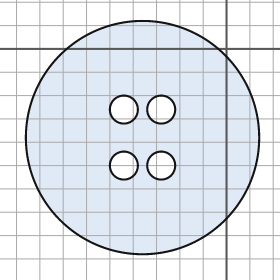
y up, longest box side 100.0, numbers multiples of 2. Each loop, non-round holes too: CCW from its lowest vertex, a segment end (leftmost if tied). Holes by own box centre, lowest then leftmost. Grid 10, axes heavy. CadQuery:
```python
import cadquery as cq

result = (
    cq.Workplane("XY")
    .moveTo(-36.0, -38.0)
    .circle(50.0)
    .moveTo(-44.0, -50.0)
    .circle(6.0)
    .moveTo(-28.0, -50.0)
    .circle(6.0)
    .moveTo(-44.0, -26.0)
    .circle(6.0)
    .moveTo(-28.0, -26.0)
    .circle(6.0)
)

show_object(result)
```